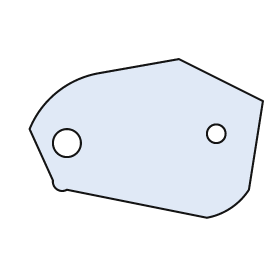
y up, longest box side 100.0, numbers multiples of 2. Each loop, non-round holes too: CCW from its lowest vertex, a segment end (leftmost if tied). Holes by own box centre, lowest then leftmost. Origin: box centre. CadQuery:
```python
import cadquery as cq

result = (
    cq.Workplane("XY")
    .moveTo(26.0, -34.0)
    .threePointArc((36.0, -30.0), (44.0, -22.0))
    .lineTo(50.0, 16.0)
    .lineTo(14.0, 34.0)
    .lineTo(-20.0, 28.0)
    .threePointArc((-38.0, 20.0), (-50.0, 4.0))
    .lineTo(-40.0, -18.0)
    .threePointArc((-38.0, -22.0), (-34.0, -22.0))
    .close()
    .moveTo(-34.0, -2.0)
    .circle(6.0)
    .moveTo(30.0, 2.0)
    .circle(4.0)
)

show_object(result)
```